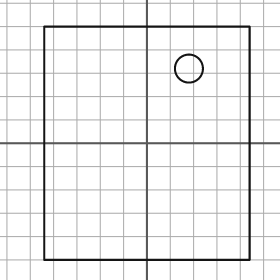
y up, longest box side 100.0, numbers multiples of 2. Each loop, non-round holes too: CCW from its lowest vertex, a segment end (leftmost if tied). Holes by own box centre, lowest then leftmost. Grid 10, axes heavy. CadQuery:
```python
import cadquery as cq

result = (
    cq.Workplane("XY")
    .moveTo(-44.0, -50.0)
    .lineTo(44.0, -50.0)
    .lineTo(44.0, 50.0)
    .lineTo(-44.0, 50.0)
    .close()
    .moveTo(18.0, 32.0)
    .circle(6.0)
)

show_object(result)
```